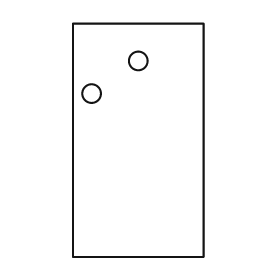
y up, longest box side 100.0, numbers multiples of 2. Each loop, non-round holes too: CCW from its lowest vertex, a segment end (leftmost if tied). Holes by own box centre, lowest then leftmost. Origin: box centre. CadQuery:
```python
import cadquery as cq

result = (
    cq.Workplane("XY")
    .moveTo(-28.0, -50.0)
    .lineTo(28.0, -50.0)
    .lineTo(28.0, 50.0)
    .lineTo(-28.0, 50.0)
    .close()
    .moveTo(-20.0, 20.0)
    .circle(4.0)
    .moveTo(0.0, 34.0)
    .circle(4.0)
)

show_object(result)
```